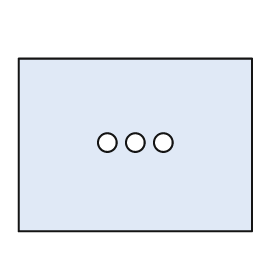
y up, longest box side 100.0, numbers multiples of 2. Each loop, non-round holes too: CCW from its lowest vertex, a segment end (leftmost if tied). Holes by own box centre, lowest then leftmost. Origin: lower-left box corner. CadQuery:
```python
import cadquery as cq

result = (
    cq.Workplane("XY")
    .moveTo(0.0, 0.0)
    .lineTo(100.0, 0.0)
    .lineTo(100.0, 74.0)
    .lineTo(0.0, 74.0)
    .close()
    .moveTo(38.0, 38.0)
    .circle(4.0)
    .moveTo(50.0, 38.0)
    .circle(4.0)
    .moveTo(62.0, 38.0)
    .circle(4.0)
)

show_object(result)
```